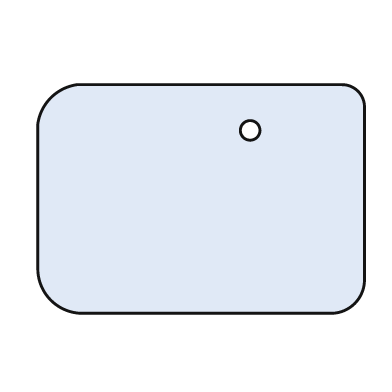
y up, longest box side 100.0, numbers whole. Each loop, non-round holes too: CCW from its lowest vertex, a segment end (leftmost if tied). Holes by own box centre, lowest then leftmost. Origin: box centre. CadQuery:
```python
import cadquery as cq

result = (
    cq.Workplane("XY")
    .moveTo(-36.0, -35.0)
    .lineTo(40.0, -35.0)
    .threePointArc((47.0, -32.0), (50.0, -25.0))
    .lineTo(50.0, 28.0)
    .threePointArc((48.0, 33.0), (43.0, 35.0))
    .lineTo(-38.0, 35.0)
    .threePointArc((-46.0, 31.0), (-50.0, 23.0))
    .lineTo(-50.0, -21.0)
    .threePointArc((-46.0, -31.0), (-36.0, -35.0))
    .close()
    .moveTo(15.0, 21.0)
    .circle(3.0)
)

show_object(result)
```